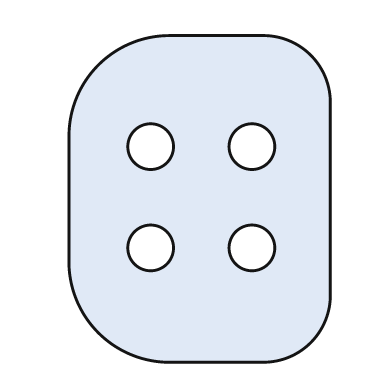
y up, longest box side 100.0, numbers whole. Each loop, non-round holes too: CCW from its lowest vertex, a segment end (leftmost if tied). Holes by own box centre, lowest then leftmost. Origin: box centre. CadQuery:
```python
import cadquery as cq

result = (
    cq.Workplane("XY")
    .moveTo(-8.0, -50.0)
    .lineTo(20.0, -50.0)
    .threePointArc((34.0, -44.0), (40.0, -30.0))
    .lineTo(40.0, 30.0)
    .threePointArc((34.0, 44.0), (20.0, 50.0))
    .lineTo(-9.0, 50.0)
    .threePointArc((-31.0, 41.0), (-40.0, 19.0))
    .lineTo(-40.0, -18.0)
    .threePointArc((-31.0, -41.0), (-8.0, -50.0))
    .close()
    .moveTo(-15.0, -15.0)
    .circle(7.0)
    .moveTo(16.0, -15.0)
    .circle(7.0)
    .moveTo(-15.0, 16.0)
    .circle(7.0)
    .moveTo(16.0, 16.0)
    .circle(7.0)
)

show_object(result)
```